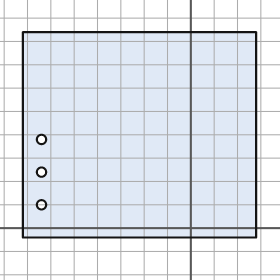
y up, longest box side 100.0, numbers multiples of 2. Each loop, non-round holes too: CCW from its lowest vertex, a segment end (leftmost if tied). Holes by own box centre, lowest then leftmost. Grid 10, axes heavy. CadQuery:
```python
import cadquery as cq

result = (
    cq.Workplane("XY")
    .moveTo(-72.0, -4.0)
    .lineTo(28.0, -4.0)
    .lineTo(28.0, 84.0)
    .lineTo(-72.0, 84.0)
    .close()
    .moveTo(-64.0, 10.0)
    .circle(2.0)
    .moveTo(-64.0, 24.0)
    .circle(2.0)
    .moveTo(-64.0, 38.0)
    .circle(2.0)
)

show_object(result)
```